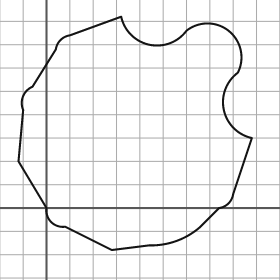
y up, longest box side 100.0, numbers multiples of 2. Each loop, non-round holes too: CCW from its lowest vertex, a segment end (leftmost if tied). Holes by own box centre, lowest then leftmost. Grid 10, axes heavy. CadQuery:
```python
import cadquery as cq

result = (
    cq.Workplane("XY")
    .moveTo(28.0, -18.0)
    .lineTo(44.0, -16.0)
    .threePointArc((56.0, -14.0), (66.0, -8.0))
    .lineTo(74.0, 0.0)
    .threePointArc((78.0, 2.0), (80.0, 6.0))
    .lineTo(88.0, 30.0)
    .threePointArc((76.0, 42.0), (82.0, 58.0))
    .threePointArc((78.0, 76.0), (60.0, 76.0))
    .threePointArc((44.0, 70.0), (32.0, 82.0))
    .lineTo(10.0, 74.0)
    .threePointArc((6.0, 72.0), (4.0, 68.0))
    .lineTo(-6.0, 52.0)
    .threePointArc((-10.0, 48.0), (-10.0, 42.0))
    .lineTo(-12.0, 20.0)
    .lineTo(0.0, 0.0)
    .threePointArc((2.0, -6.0), (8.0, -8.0))
    .close()
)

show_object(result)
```